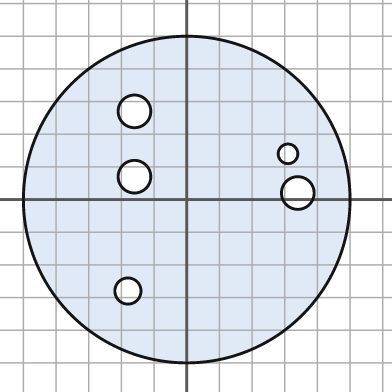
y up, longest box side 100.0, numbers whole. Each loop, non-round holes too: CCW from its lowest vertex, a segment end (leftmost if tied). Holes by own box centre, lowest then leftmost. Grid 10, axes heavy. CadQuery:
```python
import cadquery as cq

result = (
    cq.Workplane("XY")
    .moveTo(0.0, 0.0)
    .circle(50.0)
    .moveTo(-18.0, -28.0)
    .circle(4.0)
    .moveTo(34.0, 2.0)
    .circle(5.0)
    .moveTo(-16.0, 7.0)
    .circle(5.0)
    .moveTo(31.0, 14.0)
    .circle(3.0)
    .moveTo(-16.0, 27.0)
    .circle(5.0)
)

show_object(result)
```